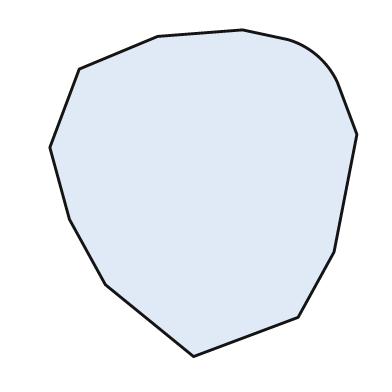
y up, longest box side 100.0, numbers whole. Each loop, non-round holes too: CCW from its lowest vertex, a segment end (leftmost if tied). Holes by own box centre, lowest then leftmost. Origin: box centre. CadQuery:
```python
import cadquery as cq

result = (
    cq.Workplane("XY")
    .moveTo(-3.0, -50.0)
    .lineTo(29.0, -38.0)
    .lineTo(40.0, -18.0)
    .lineTo(47.0, 18.0)
    .lineTo(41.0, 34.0)
    .threePointArc((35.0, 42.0), (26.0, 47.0))
    .lineTo(12.0, 50.0)
    .lineTo(-14.0, 48.0)
    .lineTo(-38.0, 38.0)
    .lineTo(-47.0, 14.0)
    .lineTo(-41.0, -8.0)
    .lineTo(-30.0, -28.0)
    .close()
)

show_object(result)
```